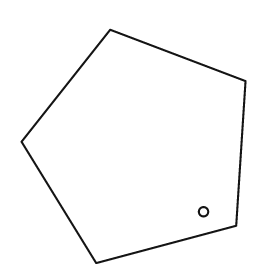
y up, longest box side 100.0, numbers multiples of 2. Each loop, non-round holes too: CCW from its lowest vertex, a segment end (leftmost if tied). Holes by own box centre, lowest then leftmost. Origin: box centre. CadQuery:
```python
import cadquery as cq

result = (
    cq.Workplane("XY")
    .moveTo(-16.0, -50.0)
    .lineTo(44.0, -34.0)
    .lineTo(48.0, 28.0)
    .lineTo(-10.0, 50.0)
    .lineTo(-48.0, 2.0)
    .close()
    .moveTo(30.0, -28.0)
    .circle(2.0)
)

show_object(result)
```